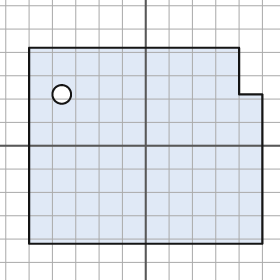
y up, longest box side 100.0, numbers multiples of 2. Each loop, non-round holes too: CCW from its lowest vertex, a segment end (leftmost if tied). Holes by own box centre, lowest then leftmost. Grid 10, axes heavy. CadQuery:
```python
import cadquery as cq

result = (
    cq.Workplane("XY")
    .moveTo(-50.0, -42.0)
    .lineTo(50.0, -42.0)
    .lineTo(50.0, 22.0)
    .lineTo(40.0, 22.0)
    .lineTo(40.0, 42.0)
    .lineTo(-50.0, 42.0)
    .close()
    .moveTo(-36.0, 22.0)
    .circle(4.0)
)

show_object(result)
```